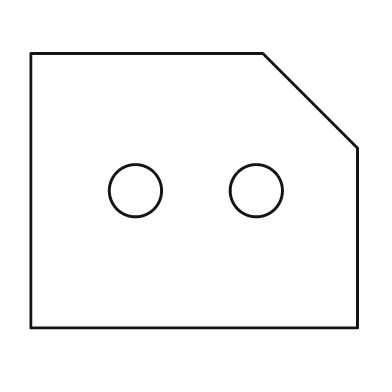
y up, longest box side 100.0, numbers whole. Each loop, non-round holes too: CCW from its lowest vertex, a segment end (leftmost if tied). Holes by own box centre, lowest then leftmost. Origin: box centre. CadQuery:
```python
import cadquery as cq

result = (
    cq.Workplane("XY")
    .moveTo(-50.0, -42.0)
    .lineTo(50.0, -42.0)
    .lineTo(50.0, 13.0)
    .lineTo(21.0, 42.0)
    .lineTo(-50.0, 42.0)
    .close()
    .moveTo(-18.0, 0.0)
    .circle(8.0)
    .moveTo(19.0, 0.0)
    .circle(8.0)
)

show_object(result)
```